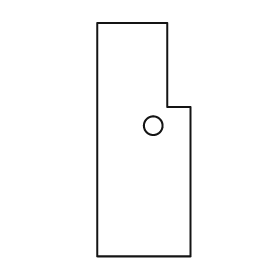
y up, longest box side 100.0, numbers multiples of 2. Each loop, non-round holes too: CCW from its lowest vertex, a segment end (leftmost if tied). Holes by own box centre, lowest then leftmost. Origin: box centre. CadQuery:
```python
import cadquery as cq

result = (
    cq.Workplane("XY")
    .moveTo(-20.0, -50.0)
    .lineTo(20.0, -50.0)
    .lineTo(20.0, 14.0)
    .lineTo(10.0, 14.0)
    .lineTo(10.0, 50.0)
    .lineTo(-20.0, 50.0)
    .close()
    .moveTo(4.0, 6.0)
    .circle(4.0)
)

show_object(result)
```